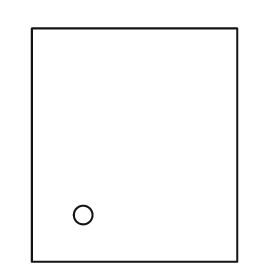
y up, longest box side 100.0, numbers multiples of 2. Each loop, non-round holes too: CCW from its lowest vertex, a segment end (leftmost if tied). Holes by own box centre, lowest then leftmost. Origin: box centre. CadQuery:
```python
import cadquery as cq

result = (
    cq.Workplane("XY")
    .moveTo(-44.0, -50.0)
    .lineTo(44.0, -50.0)
    .lineTo(44.0, 50.0)
    .lineTo(-44.0, 50.0)
    .close()
    .moveTo(-22.0, -30.0)
    .circle(4.0)
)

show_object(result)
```